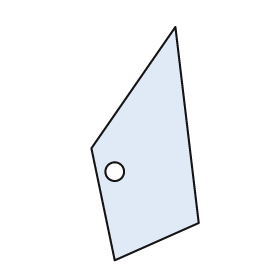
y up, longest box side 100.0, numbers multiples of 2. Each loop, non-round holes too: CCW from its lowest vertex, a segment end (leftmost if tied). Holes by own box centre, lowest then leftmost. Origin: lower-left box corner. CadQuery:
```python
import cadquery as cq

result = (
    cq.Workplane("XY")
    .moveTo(10.0, 0.0)
    .lineTo(46.0, 16.0)
    .lineTo(36.0, 100.0)
    .lineTo(0.0, 48.0)
    .close()
    .moveTo(10.0, 38.0)
    .circle(4.0)
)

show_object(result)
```